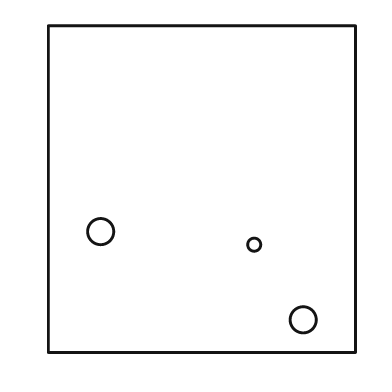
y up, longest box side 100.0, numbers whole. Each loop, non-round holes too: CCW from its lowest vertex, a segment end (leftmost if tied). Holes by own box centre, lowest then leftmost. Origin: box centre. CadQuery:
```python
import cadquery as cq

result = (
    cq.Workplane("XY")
    .moveTo(-47.0, -50.0)
    .lineTo(47.0, -50.0)
    .lineTo(47.0, 50.0)
    .lineTo(-47.0, 50.0)
    .close()
    .moveTo(31.0, -40.0)
    .circle(4.0)
    .moveTo(16.0, -17.0)
    .circle(2.0)
    .moveTo(-31.0, -13.0)
    .circle(4.0)
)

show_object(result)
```